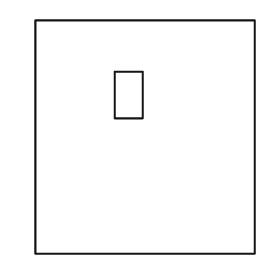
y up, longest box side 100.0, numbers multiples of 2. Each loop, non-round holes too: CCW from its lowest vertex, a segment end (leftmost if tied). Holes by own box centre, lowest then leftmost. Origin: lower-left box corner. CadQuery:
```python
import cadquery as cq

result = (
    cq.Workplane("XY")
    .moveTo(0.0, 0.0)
    .lineTo(94.0, 0.0)
    .lineTo(94.0, 100.0)
    .lineTo(0.0, 100.0)
    .close()
    .moveTo(34.0, 58.0)
    .lineTo(46.0, 58.0)
    .lineTo(46.0, 78.0)
    .lineTo(34.0, 78.0)
    .close()
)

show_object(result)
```